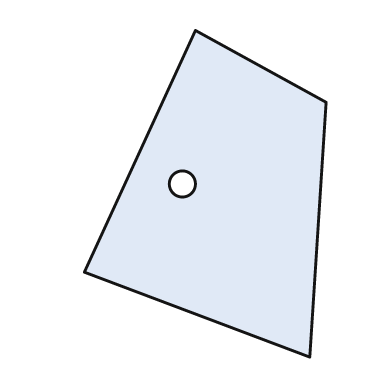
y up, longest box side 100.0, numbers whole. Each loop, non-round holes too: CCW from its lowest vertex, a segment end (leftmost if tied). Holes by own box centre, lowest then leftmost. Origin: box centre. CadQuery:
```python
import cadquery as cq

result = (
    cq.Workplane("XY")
    .moveTo(32.0, -50.0)
    .lineTo(37.0, 28.0)
    .lineTo(-3.0, 50.0)
    .lineTo(-37.0, -24.0)
    .close()
    .moveTo(-7.0, 3.0)
    .circle(4.0)
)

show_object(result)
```